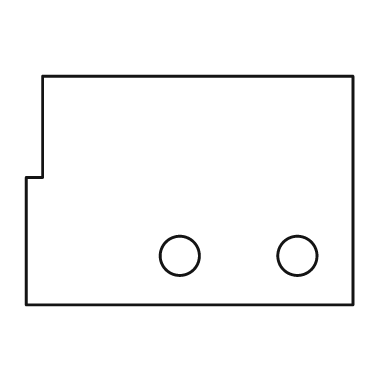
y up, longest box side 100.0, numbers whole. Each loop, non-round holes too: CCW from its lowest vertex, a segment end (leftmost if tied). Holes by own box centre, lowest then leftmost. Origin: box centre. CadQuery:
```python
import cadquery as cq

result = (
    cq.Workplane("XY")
    .moveTo(-50.0, -35.0)
    .lineTo(50.0, -35.0)
    .lineTo(50.0, 35.0)
    .lineTo(-45.0, 35.0)
    .lineTo(-45.0, 4.0)
    .lineTo(-50.0, 4.0)
    .close()
    .moveTo(-3.0, -20.0)
    .circle(6.0)
    .moveTo(33.0, -20.0)
    .circle(6.0)
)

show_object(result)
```